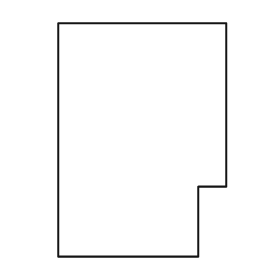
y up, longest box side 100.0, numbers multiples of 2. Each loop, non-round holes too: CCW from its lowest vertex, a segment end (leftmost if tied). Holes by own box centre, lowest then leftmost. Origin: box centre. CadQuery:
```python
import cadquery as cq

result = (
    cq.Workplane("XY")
    .moveTo(-36.0, -50.0)
    .lineTo(24.0, -50.0)
    .lineTo(24.0, -20.0)
    .lineTo(36.0, -20.0)
    .lineTo(36.0, 50.0)
    .lineTo(-36.0, 50.0)
    .close()
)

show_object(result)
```